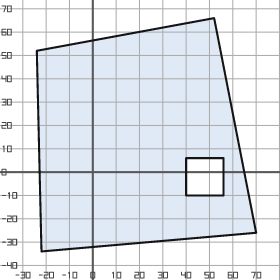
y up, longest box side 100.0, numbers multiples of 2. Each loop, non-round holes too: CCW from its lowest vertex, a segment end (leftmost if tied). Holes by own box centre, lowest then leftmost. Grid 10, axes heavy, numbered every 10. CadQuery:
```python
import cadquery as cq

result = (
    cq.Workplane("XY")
    .moveTo(-22.0, -34.0)
    .lineTo(70.0, -26.0)
    .lineTo(52.0, 66.0)
    .lineTo(-24.0, 52.0)
    .close()
    .moveTo(40.0, -10.0)
    .lineTo(56.0, -10.0)
    .lineTo(56.0, 6.0)
    .lineTo(40.0, 6.0)
    .close()
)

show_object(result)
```